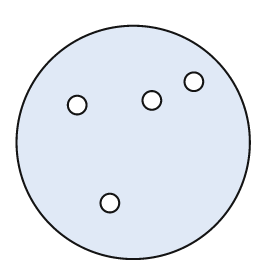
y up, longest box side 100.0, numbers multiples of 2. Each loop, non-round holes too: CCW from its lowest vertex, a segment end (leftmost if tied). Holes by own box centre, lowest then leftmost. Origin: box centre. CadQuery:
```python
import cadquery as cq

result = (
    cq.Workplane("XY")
    .moveTo(0.0, 0.0)
    .circle(50.0)
    .moveTo(-10.0, -26.0)
    .circle(4.0)
    .moveTo(-24.0, 16.0)
    .circle(4.0)
    .moveTo(8.0, 18.0)
    .circle(4.0)
    .moveTo(26.0, 26.0)
    .circle(4.0)
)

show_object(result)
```